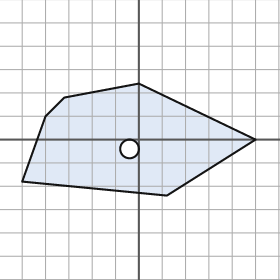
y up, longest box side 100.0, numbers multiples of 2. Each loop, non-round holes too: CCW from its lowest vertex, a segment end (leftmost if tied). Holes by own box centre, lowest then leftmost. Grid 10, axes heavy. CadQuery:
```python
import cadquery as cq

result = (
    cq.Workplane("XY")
    .moveTo(12.0, -24.0)
    .lineTo(50.0, 0.0)
    .lineTo(0.0, 24.0)
    .lineTo(-32.0, 18.0)
    .lineTo(-40.0, 10.0)
    .lineTo(-50.0, -18.0)
    .close()
    .moveTo(-4.0, -4.0)
    .circle(4.0)
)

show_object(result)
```